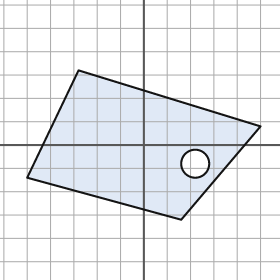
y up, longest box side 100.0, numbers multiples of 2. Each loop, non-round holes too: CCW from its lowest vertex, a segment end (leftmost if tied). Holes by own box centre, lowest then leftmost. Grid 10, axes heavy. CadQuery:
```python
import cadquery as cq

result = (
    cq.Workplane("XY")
    .moveTo(16.0, -32.0)
    .lineTo(50.0, 8.0)
    .lineTo(-28.0, 32.0)
    .lineTo(-50.0, -14.0)
    .close()
    .moveTo(22.0, -8.0)
    .circle(6.0)
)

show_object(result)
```